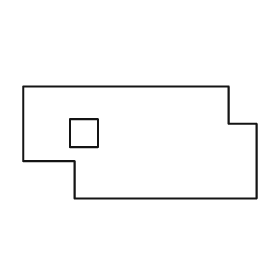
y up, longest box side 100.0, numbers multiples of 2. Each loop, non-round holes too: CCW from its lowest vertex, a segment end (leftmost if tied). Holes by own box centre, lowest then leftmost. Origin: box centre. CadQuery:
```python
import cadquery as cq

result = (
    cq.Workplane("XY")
    .moveTo(-28.0, -24.0)
    .lineTo(50.0, -24.0)
    .lineTo(50.0, 8.0)
    .lineTo(38.0, 8.0)
    .lineTo(38.0, 24.0)
    .lineTo(-50.0, 24.0)
    .lineTo(-50.0, -8.0)
    .lineTo(-28.0, -8.0)
    .close()
    .moveTo(-30.0, -2.0)
    .lineTo(-18.0, -2.0)
    .lineTo(-18.0, 10.0)
    .lineTo(-30.0, 10.0)
    .close()
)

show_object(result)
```